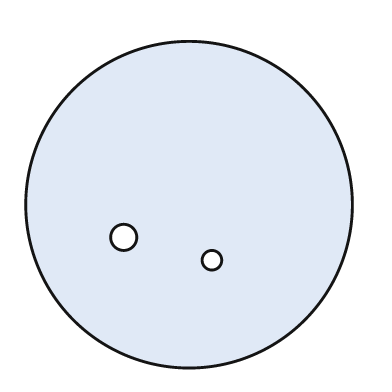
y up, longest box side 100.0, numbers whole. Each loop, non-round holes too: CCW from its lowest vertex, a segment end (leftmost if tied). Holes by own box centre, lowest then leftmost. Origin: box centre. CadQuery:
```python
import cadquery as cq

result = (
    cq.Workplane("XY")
    .moveTo(0.0, 0.0)
    .circle(50.0)
    .moveTo(7.0, -17.0)
    .circle(3.0)
    .moveTo(-20.0, -10.0)
    .circle(4.0)
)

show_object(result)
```